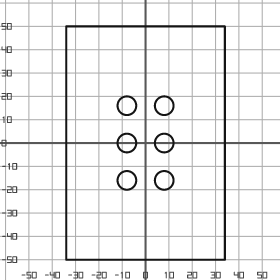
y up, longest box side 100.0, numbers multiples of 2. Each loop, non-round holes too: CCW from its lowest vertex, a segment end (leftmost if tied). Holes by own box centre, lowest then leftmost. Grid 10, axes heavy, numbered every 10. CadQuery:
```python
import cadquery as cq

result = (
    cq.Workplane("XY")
    .moveTo(-34.0, -50.0)
    .lineTo(34.0, -50.0)
    .lineTo(34.0, 50.0)
    .lineTo(-34.0, 50.0)
    .close()
    .moveTo(-8.0, -16.0)
    .circle(4.0)
    .moveTo(8.0, -16.0)
    .circle(4.0)
    .moveTo(-8.0, 0.0)
    .circle(4.0)
    .moveTo(8.0, 0.0)
    .circle(4.0)
    .moveTo(-8.0, 16.0)
    .circle(4.0)
    .moveTo(8.0, 16.0)
    .circle(4.0)
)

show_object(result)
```